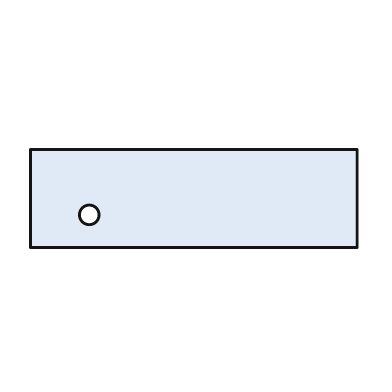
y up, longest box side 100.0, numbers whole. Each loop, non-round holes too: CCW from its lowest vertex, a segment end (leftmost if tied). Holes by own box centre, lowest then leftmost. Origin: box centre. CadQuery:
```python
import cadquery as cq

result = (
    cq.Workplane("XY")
    .moveTo(-50.0, -15.0)
    .lineTo(50.0, -15.0)
    .lineTo(50.0, 15.0)
    .lineTo(-50.0, 15.0)
    .close()
    .moveTo(-32.0, -5.0)
    .circle(3.0)
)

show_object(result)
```